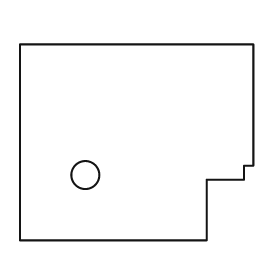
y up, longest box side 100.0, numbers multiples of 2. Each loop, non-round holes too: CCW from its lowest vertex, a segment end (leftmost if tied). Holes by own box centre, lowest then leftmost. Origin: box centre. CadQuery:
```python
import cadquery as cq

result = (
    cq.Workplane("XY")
    .moveTo(-50.0, -42.0)
    .lineTo(30.0, -42.0)
    .lineTo(30.0, -16.0)
    .lineTo(46.0, -16.0)
    .lineTo(46.0, -10.0)
    .lineTo(50.0, -10.0)
    .lineTo(50.0, 42.0)
    .lineTo(-50.0, 42.0)
    .close()
    .moveTo(-22.0, -14.0)
    .circle(6.0)
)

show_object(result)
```